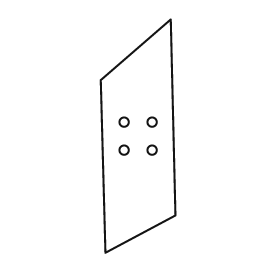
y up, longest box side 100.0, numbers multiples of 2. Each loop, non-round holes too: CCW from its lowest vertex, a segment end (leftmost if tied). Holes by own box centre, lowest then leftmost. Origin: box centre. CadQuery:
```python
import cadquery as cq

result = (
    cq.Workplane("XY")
    .moveTo(-14.0, -50.0)
    .lineTo(16.0, -34.0)
    .lineTo(14.0, 50.0)
    .lineTo(-16.0, 24.0)
    .close()
    .moveTo(-6.0, -6.0)
    .circle(2.0)
    .moveTo(6.0, -6.0)
    .circle(2.0)
    .moveTo(-6.0, 6.0)
    .circle(2.0)
    .moveTo(6.0, 6.0)
    .circle(2.0)
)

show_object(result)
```